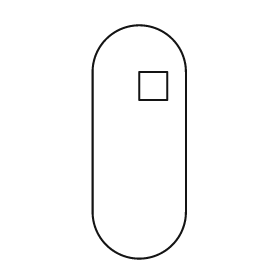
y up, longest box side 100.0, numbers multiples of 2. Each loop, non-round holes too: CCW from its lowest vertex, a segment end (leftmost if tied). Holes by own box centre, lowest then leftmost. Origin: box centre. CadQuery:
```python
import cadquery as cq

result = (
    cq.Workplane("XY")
    .moveTo(-20.0, -30.0)
    .threePointArc((0.0, -50.0), (20.0, -30.0))
    .lineTo(20.0, 30.0)
    .threePointArc((0.0, 50.0), (-20.0, 30.0))
    .close()
    .moveTo(0.0, 18.0)
    .lineTo(12.0, 18.0)
    .lineTo(12.0, 30.0)
    .lineTo(0.0, 30.0)
    .close()
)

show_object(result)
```